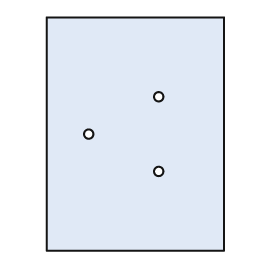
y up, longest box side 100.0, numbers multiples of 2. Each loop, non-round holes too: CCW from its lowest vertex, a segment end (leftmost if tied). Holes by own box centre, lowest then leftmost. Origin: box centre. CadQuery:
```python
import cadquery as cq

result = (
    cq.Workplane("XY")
    .moveTo(-38.0, -50.0)
    .lineTo(38.0, -50.0)
    .lineTo(38.0, 50.0)
    .lineTo(-38.0, 50.0)
    .close()
    .moveTo(10.0, -16.0)
    .circle(2.0)
    .moveTo(-20.0, 0.0)
    .circle(2.0)
    .moveTo(10.0, 16.0)
    .circle(2.0)
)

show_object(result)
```